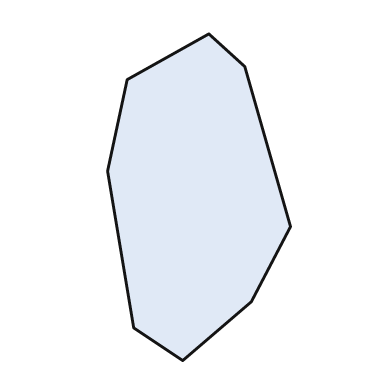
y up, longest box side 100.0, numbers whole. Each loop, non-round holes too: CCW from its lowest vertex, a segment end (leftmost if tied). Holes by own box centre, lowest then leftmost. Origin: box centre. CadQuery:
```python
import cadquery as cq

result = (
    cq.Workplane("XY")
    .moveTo(-5.0, -50.0)
    .lineTo(16.0, -32.0)
    .lineTo(28.0, -9.0)
    .lineTo(14.0, 40.0)
    .lineTo(3.0, 50.0)
    .lineTo(-22.0, 36.0)
    .lineTo(-28.0, 8.0)
    .lineTo(-20.0, -40.0)
    .close()
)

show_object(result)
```